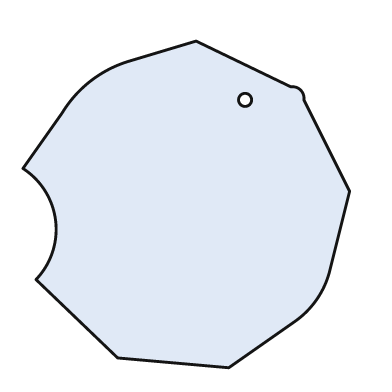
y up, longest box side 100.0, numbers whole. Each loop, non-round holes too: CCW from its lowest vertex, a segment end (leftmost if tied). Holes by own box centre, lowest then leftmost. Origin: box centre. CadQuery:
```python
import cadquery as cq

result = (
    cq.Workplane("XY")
    .moveTo(13.0, -50.0)
    .lineTo(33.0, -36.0)
    .threePointArc((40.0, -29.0), (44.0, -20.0))
    .lineTo(50.0, 4.0)
    .lineTo(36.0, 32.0)
    .threePointArc((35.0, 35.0), (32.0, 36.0))
    .lineTo(3.0, 50.0)
    .lineTo(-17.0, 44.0)
    .threePointArc((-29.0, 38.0), (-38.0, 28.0))
    .lineTo(-50.0, 11.0)
    .threePointArc((-40.0, -5.0), (-46.0, -23.0))
    .lineTo(-21.0, -47.0)
    .close()
    .moveTo(18.0, 32.0)
    .circle(2.0)
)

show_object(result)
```